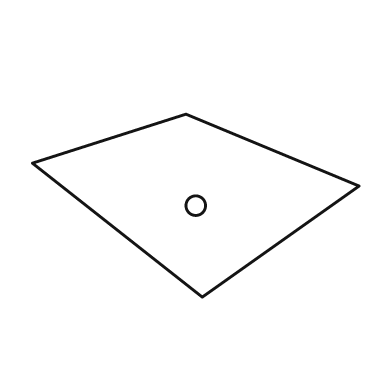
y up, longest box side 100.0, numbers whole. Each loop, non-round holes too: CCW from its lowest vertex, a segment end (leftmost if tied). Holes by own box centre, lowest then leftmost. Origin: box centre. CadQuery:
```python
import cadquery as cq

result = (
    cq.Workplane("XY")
    .moveTo(2.0, -28.0)
    .lineTo(50.0, 6.0)
    .lineTo(-3.0, 28.0)
    .lineTo(-50.0, 13.0)
    .close()
    .moveTo(0.0, 0.0)
    .circle(3.0)
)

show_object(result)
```